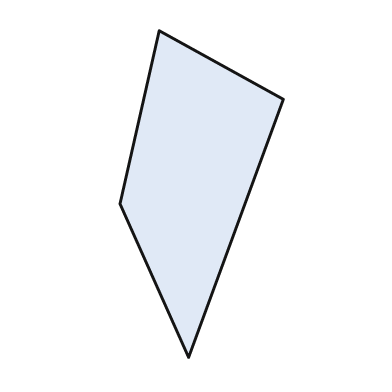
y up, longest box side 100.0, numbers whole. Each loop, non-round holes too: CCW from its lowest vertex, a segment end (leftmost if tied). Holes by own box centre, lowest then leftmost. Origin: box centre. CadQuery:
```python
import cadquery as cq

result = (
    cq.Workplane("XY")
    .moveTo(-4.0, -50.0)
    .lineTo(25.0, 29.0)
    .lineTo(-13.0, 50.0)
    .lineTo(-25.0, -3.0)
    .close()
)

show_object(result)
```